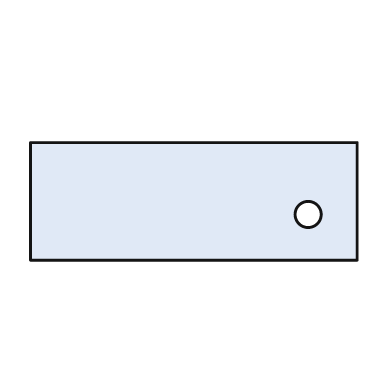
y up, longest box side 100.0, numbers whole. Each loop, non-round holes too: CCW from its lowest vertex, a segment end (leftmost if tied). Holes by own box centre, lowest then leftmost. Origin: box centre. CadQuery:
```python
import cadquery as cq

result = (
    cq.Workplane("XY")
    .moveTo(-50.0, -18.0)
    .lineTo(50.0, -18.0)
    .lineTo(50.0, 18.0)
    .lineTo(-50.0, 18.0)
    .close()
    .moveTo(35.0, -4.0)
    .circle(4.0)
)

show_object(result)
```